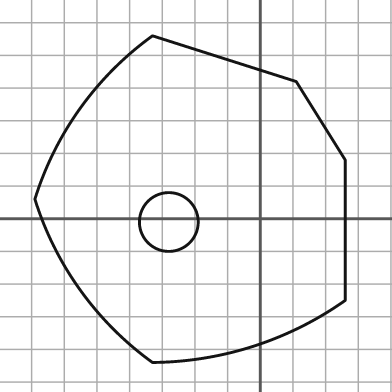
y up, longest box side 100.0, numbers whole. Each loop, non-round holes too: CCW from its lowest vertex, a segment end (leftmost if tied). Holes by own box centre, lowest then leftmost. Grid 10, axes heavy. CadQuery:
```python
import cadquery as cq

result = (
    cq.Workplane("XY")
    .moveTo(-33.0, -44.0)
    .threePointArc((-2.0, -39.0), (26.0, -25.0))
    .lineTo(26.0, 18.0)
    .lineTo(11.0, 42.0)
    .lineTo(-33.0, 56.0)
    .threePointArc((-55.0, 34.0), (-69.0, 6.0))
    .threePointArc((-55.0, -22.0), (-33.0, -44.0))
    .close()
    .moveTo(-28.0, -1.0)
    .circle(9.0)
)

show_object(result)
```